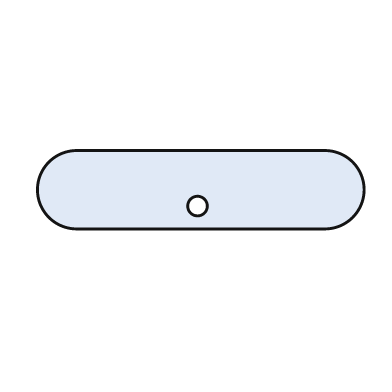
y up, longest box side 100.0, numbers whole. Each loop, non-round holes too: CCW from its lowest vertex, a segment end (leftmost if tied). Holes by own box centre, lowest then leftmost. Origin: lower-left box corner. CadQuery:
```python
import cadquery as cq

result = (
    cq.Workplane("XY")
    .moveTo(12.0, 0.0)
    .lineTo(88.0, 0.0)
    .threePointArc((100.0, 12.0), (88.0, 24.0))
    .lineTo(12.0, 24.0)
    .threePointArc((0.0, 12.0), (12.0, 0.0))
    .close()
    .moveTo(49.0, 7.0)
    .circle(3.0)
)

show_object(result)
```